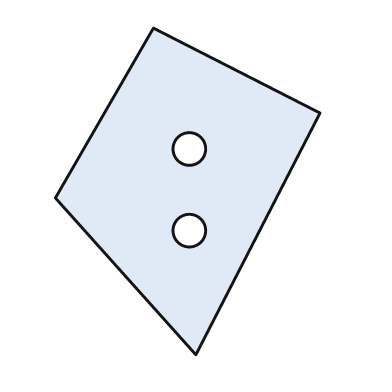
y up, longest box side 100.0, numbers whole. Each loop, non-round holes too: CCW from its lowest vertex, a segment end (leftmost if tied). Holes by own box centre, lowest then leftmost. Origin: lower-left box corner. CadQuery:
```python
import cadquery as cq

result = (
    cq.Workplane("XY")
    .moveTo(43.0, 0.0)
    .lineTo(81.0, 74.0)
    .lineTo(30.0, 100.0)
    .lineTo(0.0, 48.0)
    .close()
    .moveTo(41.0, 38.0)
    .circle(5.0)
    .moveTo(41.0, 63.0)
    .circle(5.0)
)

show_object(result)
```